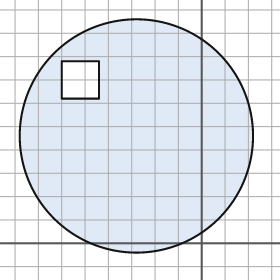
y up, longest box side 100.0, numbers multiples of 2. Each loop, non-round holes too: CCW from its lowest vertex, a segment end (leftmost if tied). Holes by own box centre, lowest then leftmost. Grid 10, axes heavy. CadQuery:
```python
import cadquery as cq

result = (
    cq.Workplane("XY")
    .moveTo(-28.0, 46.0)
    .circle(50.0)
    .moveTo(-60.0, 62.0)
    .lineTo(-44.0, 62.0)
    .lineTo(-44.0, 78.0)
    .lineTo(-60.0, 78.0)
    .close()
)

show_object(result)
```